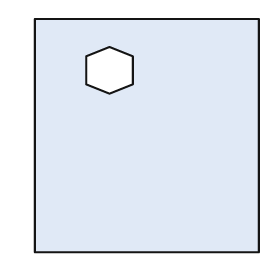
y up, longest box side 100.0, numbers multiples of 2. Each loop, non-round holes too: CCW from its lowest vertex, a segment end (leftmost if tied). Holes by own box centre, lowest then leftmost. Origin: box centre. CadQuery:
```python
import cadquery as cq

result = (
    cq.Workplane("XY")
    .moveTo(-48.0, -50.0)
    .lineTo(48.0, -50.0)
    .lineTo(48.0, 50.0)
    .lineTo(-48.0, 50.0)
    .close()
    .moveTo(-16.0, 18.0)
    .lineTo(-6.0, 22.0)
    .lineTo(-6.0, 34.0)
    .lineTo(-16.0, 38.0)
    .lineTo(-26.0, 34.0)
    .lineTo(-26.0, 22.0)
    .close()
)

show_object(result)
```